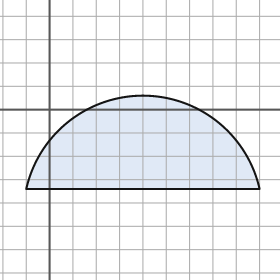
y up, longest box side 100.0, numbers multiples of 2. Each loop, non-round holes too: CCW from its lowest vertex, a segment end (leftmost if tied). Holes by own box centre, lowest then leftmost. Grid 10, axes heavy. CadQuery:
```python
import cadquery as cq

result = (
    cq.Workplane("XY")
    .moveTo(-10.0, -34.0)
    .lineTo(90.0, -34.0)
    .threePointArc((40.0, 6.0), (-10.0, -34.0))
    .close()
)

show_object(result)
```